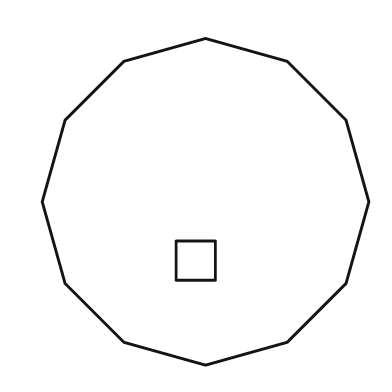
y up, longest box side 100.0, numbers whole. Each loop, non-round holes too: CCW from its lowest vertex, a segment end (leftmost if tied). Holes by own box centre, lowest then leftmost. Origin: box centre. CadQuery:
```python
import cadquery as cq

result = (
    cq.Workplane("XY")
    .moveTo(0.0, -50.0)
    .lineTo(25.0, -43.0)
    .lineTo(43.0, -25.0)
    .lineTo(50.0, 0.0)
    .lineTo(43.0, 25.0)
    .lineTo(25.0, 43.0)
    .lineTo(0.0, 50.0)
    .lineTo(-25.0, 43.0)
    .lineTo(-43.0, 25.0)
    .lineTo(-50.0, 0.0)
    .lineTo(-43.0, -25.0)
    .lineTo(-25.0, -43.0)
    .close()
    .moveTo(-9.0, -24.0)
    .lineTo(3.0, -24.0)
    .lineTo(3.0, -12.0)
    .lineTo(-9.0, -12.0)
    .close()
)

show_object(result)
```